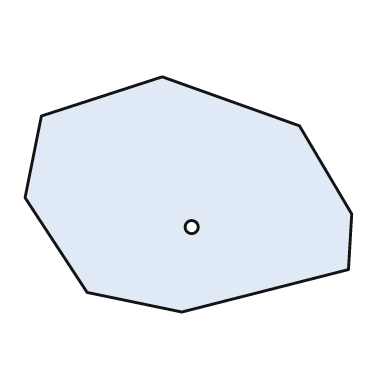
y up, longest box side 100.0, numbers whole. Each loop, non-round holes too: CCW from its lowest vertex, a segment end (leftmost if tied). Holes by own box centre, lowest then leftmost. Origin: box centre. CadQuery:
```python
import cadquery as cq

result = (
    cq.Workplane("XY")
    .moveTo(-2.0, -36.0)
    .lineTo(49.0, -23.0)
    .lineTo(50.0, -6.0)
    .lineTo(34.0, 21.0)
    .lineTo(-8.0, 36.0)
    .lineTo(-45.0, 24.0)
    .lineTo(-50.0, -1.0)
    .lineTo(-31.0, -30.0)
    .close()
    .moveTo(1.0, -10.0)
    .circle(2.0)
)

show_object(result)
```